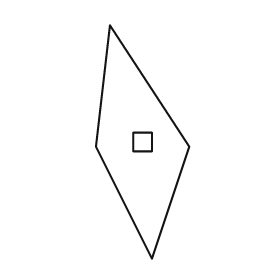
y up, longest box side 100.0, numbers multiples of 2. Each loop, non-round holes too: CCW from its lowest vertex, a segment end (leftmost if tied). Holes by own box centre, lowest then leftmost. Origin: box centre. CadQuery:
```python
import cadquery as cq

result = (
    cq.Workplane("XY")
    .moveTo(4.0, -50.0)
    .lineTo(20.0, -2.0)
    .lineTo(-14.0, 50.0)
    .lineTo(-20.0, -2.0)
    .close()
    .moveTo(-4.0, -4.0)
    .lineTo(4.0, -4.0)
    .lineTo(4.0, 4.0)
    .lineTo(-4.0, 4.0)
    .close()
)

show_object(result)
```